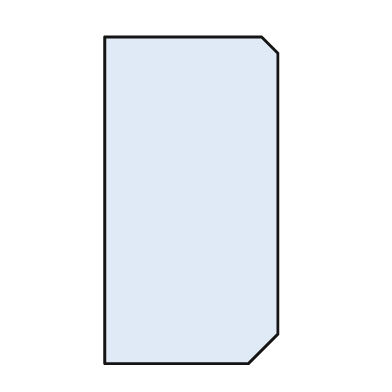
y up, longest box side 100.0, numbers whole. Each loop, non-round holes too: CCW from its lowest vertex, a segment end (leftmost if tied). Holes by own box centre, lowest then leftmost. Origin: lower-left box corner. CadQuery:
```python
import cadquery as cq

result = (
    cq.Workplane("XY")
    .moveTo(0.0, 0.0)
    .lineTo(44.0, 0.0)
    .lineTo(53.0, 9.0)
    .lineTo(53.0, 95.0)
    .lineTo(48.0, 100.0)
    .lineTo(0.0, 100.0)
    .close()
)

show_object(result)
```